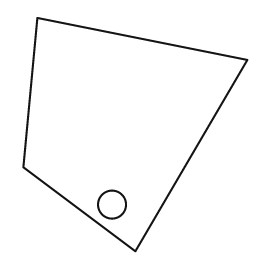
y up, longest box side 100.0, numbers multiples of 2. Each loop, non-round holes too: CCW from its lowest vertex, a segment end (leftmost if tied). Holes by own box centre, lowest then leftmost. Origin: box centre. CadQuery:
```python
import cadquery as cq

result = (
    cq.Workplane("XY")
    .moveTo(0.0, -50.0)
    .lineTo(48.0, 32.0)
    .lineTo(-42.0, 50.0)
    .lineTo(-48.0, -14.0)
    .close()
    .moveTo(-10.0, -30.0)
    .circle(6.0)
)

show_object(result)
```